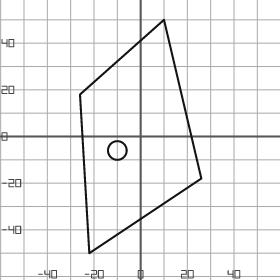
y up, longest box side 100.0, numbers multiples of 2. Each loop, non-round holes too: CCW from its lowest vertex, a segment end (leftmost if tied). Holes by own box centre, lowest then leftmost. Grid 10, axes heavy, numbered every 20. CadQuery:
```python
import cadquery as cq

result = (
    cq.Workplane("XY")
    .moveTo(-22.0, -50.0)
    .lineTo(26.0, -18.0)
    .lineTo(10.0, 50.0)
    .lineTo(-26.0, 18.0)
    .close()
    .moveTo(-10.0, -6.0)
    .circle(4.0)
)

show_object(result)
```